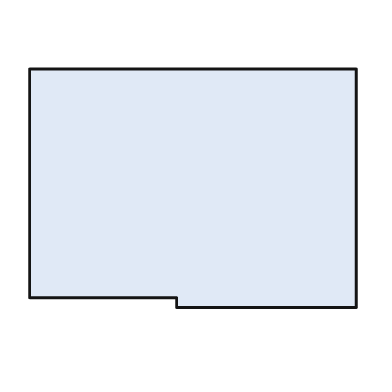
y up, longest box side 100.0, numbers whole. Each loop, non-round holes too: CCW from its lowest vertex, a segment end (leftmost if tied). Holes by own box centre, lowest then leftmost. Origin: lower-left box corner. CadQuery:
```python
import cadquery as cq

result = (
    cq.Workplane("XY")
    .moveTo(45.0, 0.0)
    .lineTo(100.0, 0.0)
    .lineTo(100.0, 73.0)
    .lineTo(0.0, 73.0)
    .lineTo(0.0, 3.0)
    .lineTo(45.0, 3.0)
    .close()
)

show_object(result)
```